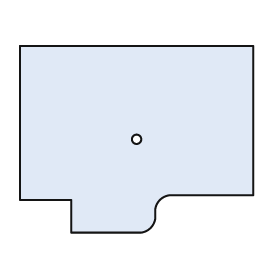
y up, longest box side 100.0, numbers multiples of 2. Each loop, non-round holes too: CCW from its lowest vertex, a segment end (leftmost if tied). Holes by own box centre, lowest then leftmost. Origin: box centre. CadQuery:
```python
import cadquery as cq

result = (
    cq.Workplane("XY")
    .moveTo(-28.0, -40.0)
    .lineTo(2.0, -40.0)
    .threePointArc((6.0, -38.0), (8.0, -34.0))
    .lineTo(8.0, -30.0)
    .threePointArc((10.0, -26.0), (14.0, -24.0))
    .lineTo(50.0, -24.0)
    .lineTo(50.0, 40.0)
    .lineTo(-50.0, 40.0)
    .lineTo(-50.0, -26.0)
    .lineTo(-28.0, -26.0)
    .close()
    .moveTo(0.0, 0.0)
    .circle(2.0)
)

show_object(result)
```